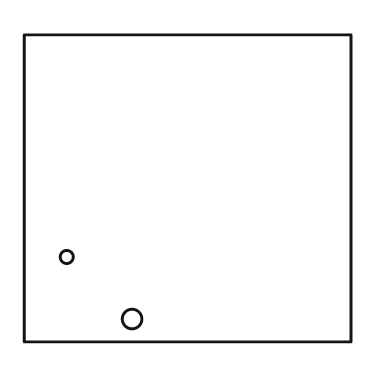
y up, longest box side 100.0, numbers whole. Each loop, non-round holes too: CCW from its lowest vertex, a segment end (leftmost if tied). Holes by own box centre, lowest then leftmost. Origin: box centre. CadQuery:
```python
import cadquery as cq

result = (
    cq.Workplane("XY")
    .moveTo(-50.0, -47.0)
    .lineTo(50.0, -47.0)
    .lineTo(50.0, 47.0)
    .lineTo(-50.0, 47.0)
    .close()
    .moveTo(-17.0, -40.0)
    .circle(3.0)
    .moveTo(-37.0, -21.0)
    .circle(2.0)
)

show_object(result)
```